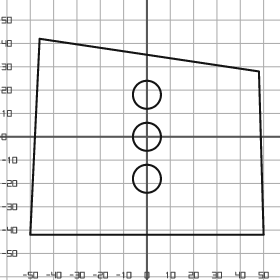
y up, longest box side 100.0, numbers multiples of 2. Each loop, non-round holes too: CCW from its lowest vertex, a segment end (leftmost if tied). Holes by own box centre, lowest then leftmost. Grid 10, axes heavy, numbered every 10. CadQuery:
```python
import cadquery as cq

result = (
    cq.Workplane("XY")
    .moveTo(-50.0, -42.0)
    .lineTo(50.0, -42.0)
    .lineTo(48.0, 28.0)
    .lineTo(-46.0, 42.0)
    .close()
    .moveTo(0.0, -18.0)
    .circle(6.0)
    .moveTo(0.0, 0.0)
    .circle(6.0)
    .moveTo(0.0, 18.0)
    .circle(6.0)
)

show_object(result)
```